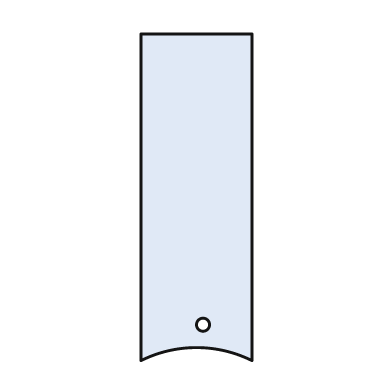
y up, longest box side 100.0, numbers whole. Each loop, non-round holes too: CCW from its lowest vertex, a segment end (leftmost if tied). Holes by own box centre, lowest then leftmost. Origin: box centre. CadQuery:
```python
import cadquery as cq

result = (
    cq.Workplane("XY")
    .moveTo(-17.0, -50.0)
    .threePointArc((0.0, -46.0), (17.0, -50.0))
    .lineTo(17.0, 50.0)
    .lineTo(-17.0, 50.0)
    .close()
    .moveTo(2.0, -39.0)
    .circle(2.0)
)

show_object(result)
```